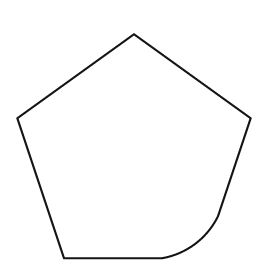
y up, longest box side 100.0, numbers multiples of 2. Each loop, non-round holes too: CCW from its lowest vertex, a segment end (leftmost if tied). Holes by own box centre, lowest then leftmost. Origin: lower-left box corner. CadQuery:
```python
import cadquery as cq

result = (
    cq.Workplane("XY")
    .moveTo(20.0, 0.0)
    .lineTo(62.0, 0.0)
    .threePointArc((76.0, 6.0), (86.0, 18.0))
    .lineTo(100.0, 60.0)
    .lineTo(50.0, 96.0)
    .lineTo(0.0, 60.0)
    .close()
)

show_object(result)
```